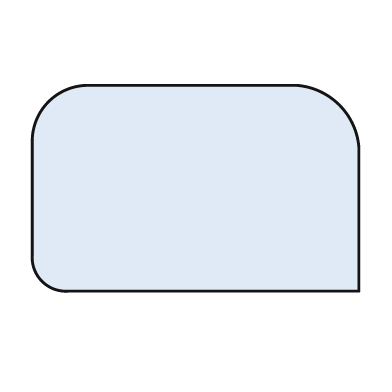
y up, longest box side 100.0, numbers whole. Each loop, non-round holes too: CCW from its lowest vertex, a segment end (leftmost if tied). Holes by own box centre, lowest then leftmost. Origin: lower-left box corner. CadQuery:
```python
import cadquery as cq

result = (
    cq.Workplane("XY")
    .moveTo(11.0, 0.0)
    .lineTo(100.0, 0.0)
    .lineTo(100.0, 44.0)
    .threePointArc((94.0, 57.0), (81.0, 63.0))
    .lineTo(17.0, 63.0)
    .threePointArc((5.0, 58.0), (0.0, 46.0))
    .lineTo(0.0, 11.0)
    .threePointArc((3.0, 3.0), (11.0, 0.0))
    .close()
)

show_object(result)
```